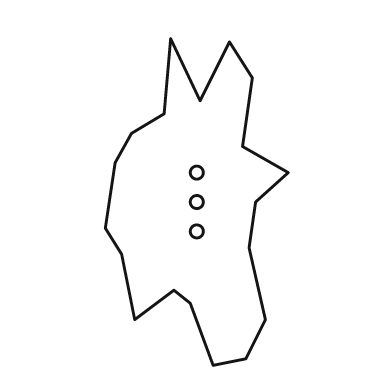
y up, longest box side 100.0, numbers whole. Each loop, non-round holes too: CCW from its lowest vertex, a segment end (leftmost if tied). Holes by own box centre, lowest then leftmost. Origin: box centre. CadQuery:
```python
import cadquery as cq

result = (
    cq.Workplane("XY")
    .moveTo(5.0, -50.0)
    .lineTo(15.0, -48.0)
    .lineTo(21.0, -36.0)
    .lineTo(16.0, -14.0)
    .lineTo(18.0, 0.0)
    .lineTo(28.0, 9.0)
    .lineTo(14.0, 17.0)
    .lineTo(17.0, 38.0)
    .lineTo(10.0, 49.0)
    .lineTo(1.0, 31.0)
    .lineTo(-8.0, 50.0)
    .lineTo(-10.0, 27.0)
    .lineTo(-20.0, 21.0)
    .lineTo(-25.0, 12.0)
    .lineTo(-28.0, -8.0)
    .lineTo(-23.0, -16.0)
    .lineTo(-19.0, -36.0)
    .lineTo(-7.0, -27.0)
    .lineTo(-2.0, -31.0)
    .close()
    .moveTo(0.0, -9.0)
    .circle(2.0)
    .moveTo(0.0, 0.0)
    .circle(2.0)
    .moveTo(0.0, 9.0)
    .circle(2.0)
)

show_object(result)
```